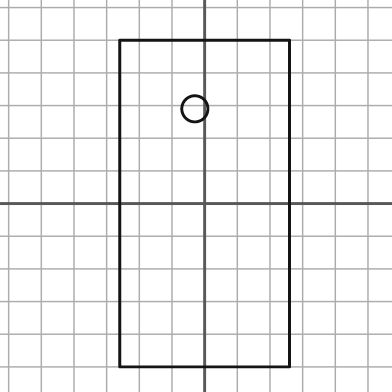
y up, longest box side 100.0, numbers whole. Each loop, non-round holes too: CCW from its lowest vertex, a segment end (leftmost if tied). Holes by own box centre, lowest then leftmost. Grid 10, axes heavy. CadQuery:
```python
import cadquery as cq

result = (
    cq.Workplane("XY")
    .moveTo(-26.0, -50.0)
    .lineTo(26.0, -50.0)
    .lineTo(26.0, 50.0)
    .lineTo(-26.0, 50.0)
    .close()
    .moveTo(-3.0, 29.0)
    .circle(4.0)
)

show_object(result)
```